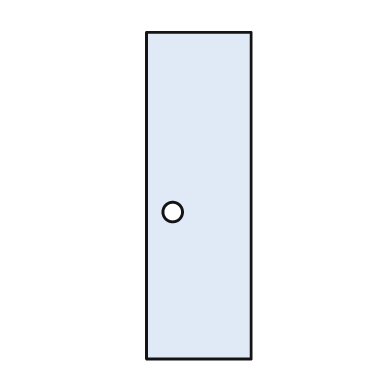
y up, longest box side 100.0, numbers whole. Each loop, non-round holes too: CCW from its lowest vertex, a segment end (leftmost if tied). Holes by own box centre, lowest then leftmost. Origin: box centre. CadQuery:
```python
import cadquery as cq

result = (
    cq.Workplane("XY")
    .moveTo(-16.0, -50.0)
    .lineTo(16.0, -50.0)
    .lineTo(16.0, 50.0)
    .lineTo(-16.0, 50.0)
    .close()
    .moveTo(-8.0, -5.0)
    .circle(3.0)
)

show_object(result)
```